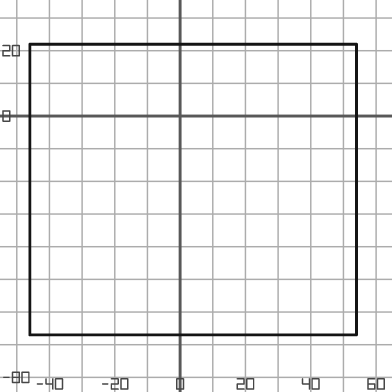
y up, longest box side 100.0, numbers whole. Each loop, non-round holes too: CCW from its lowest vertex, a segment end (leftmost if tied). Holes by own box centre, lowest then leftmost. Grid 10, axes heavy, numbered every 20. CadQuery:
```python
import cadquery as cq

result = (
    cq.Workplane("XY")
    .moveTo(-46.0, -67.0)
    .lineTo(54.0, -67.0)
    .lineTo(54.0, 22.0)
    .lineTo(-46.0, 22.0)
    .close()
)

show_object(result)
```